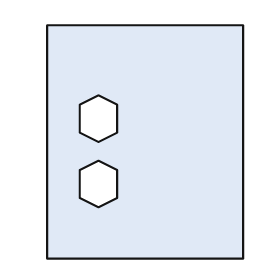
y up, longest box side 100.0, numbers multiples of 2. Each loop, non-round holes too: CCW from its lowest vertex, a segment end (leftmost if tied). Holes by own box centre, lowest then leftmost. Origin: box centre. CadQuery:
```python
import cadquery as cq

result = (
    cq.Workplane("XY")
    .moveTo(-42.0, -50.0)
    .lineTo(42.0, -50.0)
    .lineTo(42.0, 50.0)
    .lineTo(-42.0, 50.0)
    .close()
    .moveTo(-20.0, -28.0)
    .lineTo(-12.0, -24.0)
    .lineTo(-12.0, -12.0)
    .lineTo(-20.0, -8.0)
    .lineTo(-28.0, -12.0)
    .lineTo(-28.0, -24.0)
    .close()
    .moveTo(-20.0, 0.0)
    .lineTo(-12.0, 4.0)
    .lineTo(-12.0, 16.0)
    .lineTo(-20.0, 20.0)
    .lineTo(-28.0, 16.0)
    .lineTo(-28.0, 4.0)
    .close()
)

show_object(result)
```